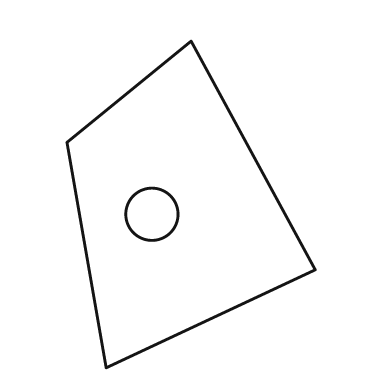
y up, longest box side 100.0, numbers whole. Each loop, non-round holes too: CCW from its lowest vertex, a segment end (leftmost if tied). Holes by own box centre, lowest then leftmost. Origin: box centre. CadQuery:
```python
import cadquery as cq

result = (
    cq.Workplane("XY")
    .moveTo(-26.0, -50.0)
    .lineTo(38.0, -20.0)
    .lineTo(0.0, 50.0)
    .lineTo(-38.0, 19.0)
    .close()
    .moveTo(-12.0, -3.0)
    .circle(8.0)
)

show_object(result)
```